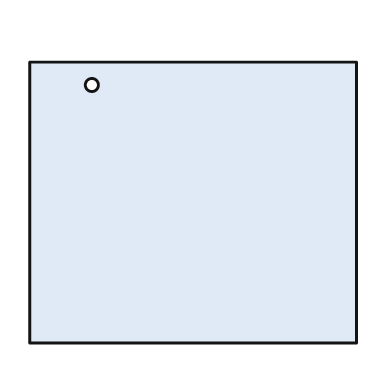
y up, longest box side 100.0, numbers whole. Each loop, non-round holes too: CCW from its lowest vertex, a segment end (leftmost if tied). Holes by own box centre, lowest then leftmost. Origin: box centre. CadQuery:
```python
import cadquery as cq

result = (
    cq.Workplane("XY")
    .moveTo(-50.0, -43.0)
    .lineTo(50.0, -43.0)
    .lineTo(50.0, 43.0)
    .lineTo(-50.0, 43.0)
    .close()
    .moveTo(-31.0, 36.0)
    .circle(2.0)
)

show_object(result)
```